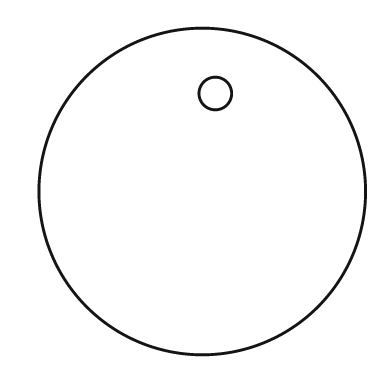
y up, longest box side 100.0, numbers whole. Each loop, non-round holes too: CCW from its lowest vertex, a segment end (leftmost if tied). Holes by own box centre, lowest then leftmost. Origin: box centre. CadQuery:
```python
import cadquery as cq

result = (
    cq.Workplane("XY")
    .moveTo(0.0, 0.0)
    .circle(50.0)
    .moveTo(4.0, 30.0)
    .circle(5.0)
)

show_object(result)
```